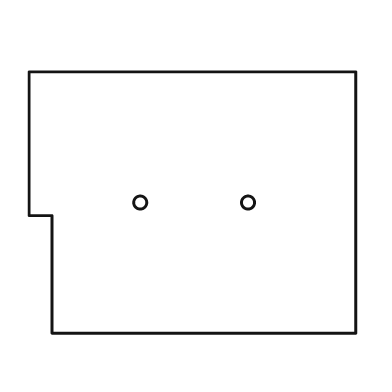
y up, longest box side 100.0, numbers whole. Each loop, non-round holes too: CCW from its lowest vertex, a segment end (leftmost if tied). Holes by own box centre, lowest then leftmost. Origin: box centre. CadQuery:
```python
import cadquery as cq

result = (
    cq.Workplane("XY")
    .moveTo(-43.0, -40.0)
    .lineTo(50.0, -40.0)
    .lineTo(50.0, 40.0)
    .lineTo(-50.0, 40.0)
    .lineTo(-50.0, -4.0)
    .lineTo(-43.0, -4.0)
    .close()
    .moveTo(-16.0, 0.0)
    .circle(2.0)
    .moveTo(17.0, 0.0)
    .circle(2.0)
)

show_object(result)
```